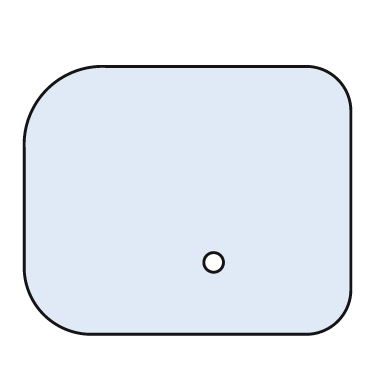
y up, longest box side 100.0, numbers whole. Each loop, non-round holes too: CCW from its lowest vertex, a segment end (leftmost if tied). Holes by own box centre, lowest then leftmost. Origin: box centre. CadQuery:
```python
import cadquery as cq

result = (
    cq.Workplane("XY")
    .moveTo(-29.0, -41.0)
    .lineTo(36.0, -41.0)
    .threePointArc((46.0, -37.0), (50.0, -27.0))
    .lineTo(50.0, 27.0)
    .threePointArc((46.0, 37.0), (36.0, 41.0))
    .lineTo(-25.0, 41.0)
    .threePointArc((-43.0, 34.0), (-50.0, 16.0))
    .lineTo(-50.0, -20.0)
    .threePointArc((-44.0, -35.0), (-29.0, -41.0))
    .close()
    .moveTo(8.0, -19.0)
    .circle(3.0)
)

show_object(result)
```